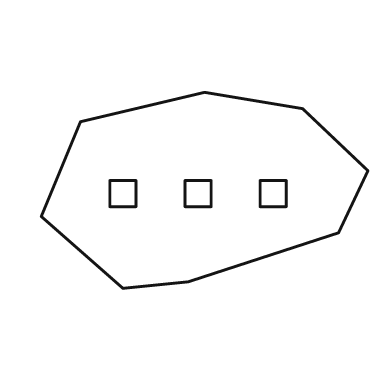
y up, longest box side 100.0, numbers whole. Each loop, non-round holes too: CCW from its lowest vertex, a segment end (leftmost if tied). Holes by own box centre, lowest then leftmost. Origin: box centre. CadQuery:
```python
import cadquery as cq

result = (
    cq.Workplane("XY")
    .moveTo(-25.0, -30.0)
    .lineTo(-5.0, -28.0)
    .lineTo(41.0, -13.0)
    .lineTo(50.0, 6.0)
    .lineTo(30.0, 25.0)
    .lineTo(0.0, 30.0)
    .lineTo(-38.0, 21.0)
    .lineTo(-50.0, -8.0)
    .close()
    .moveTo(-29.0, -5.0)
    .lineTo(-21.0, -5.0)
    .lineTo(-21.0, 3.0)
    .lineTo(-29.0, 3.0)
    .close()
    .moveTo(-6.0, -5.0)
    .lineTo(2.0, -5.0)
    .lineTo(2.0, 3.0)
    .lineTo(-6.0, 3.0)
    .close()
    .moveTo(17.0, -5.0)
    .lineTo(25.0, -5.0)
    .lineTo(25.0, 3.0)
    .lineTo(17.0, 3.0)
    .close()
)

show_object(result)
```